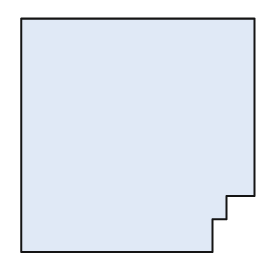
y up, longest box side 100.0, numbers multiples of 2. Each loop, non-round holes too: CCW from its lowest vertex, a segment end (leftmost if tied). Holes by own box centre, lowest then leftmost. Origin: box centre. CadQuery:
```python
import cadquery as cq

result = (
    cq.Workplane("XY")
    .moveTo(-50.0, -50.0)
    .lineTo(32.0, -50.0)
    .lineTo(32.0, -36.0)
    .lineTo(38.0, -36.0)
    .lineTo(38.0, -26.0)
    .lineTo(50.0, -26.0)
    .lineTo(50.0, 50.0)
    .lineTo(-50.0, 50.0)
    .close()
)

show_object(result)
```